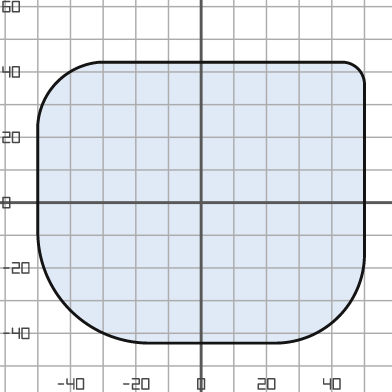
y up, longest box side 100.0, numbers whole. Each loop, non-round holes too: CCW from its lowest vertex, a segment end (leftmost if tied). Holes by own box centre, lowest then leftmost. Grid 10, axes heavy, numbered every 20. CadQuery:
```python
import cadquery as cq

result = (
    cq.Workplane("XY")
    .moveTo(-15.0, -43.0)
    .lineTo(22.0, -43.0)
    .threePointArc((42.0, -35.0), (50.0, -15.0))
    .lineTo(50.0, 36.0)
    .threePointArc((48.0, 41.0), (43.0, 43.0))
    .lineTo(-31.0, 43.0)
    .threePointArc((-44.0, 37.0), (-50.0, 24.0))
    .lineTo(-50.0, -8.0)
    .threePointArc((-40.0, -33.0), (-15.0, -43.0))
    .close()
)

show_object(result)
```